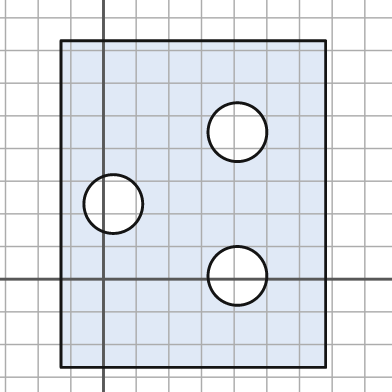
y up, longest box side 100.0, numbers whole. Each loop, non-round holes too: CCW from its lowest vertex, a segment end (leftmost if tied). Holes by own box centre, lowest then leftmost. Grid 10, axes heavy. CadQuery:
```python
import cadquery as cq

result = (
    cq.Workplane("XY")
    .moveTo(-13.0, -27.0)
    .lineTo(68.0, -27.0)
    .lineTo(68.0, 73.0)
    .lineTo(-13.0, 73.0)
    .close()
    .moveTo(41.0, 1.0)
    .circle(9.0)
    .moveTo(3.0, 23.0)
    .circle(9.0)
    .moveTo(41.0, 45.0)
    .circle(9.0)
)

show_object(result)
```